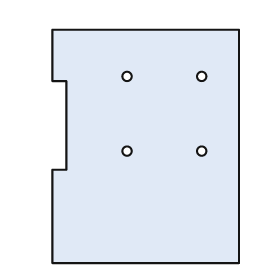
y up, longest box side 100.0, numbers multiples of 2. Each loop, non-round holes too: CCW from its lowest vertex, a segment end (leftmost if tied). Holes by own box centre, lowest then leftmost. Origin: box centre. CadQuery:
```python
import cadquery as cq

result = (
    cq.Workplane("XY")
    .moveTo(-40.0, -50.0)
    .lineTo(40.0, -50.0)
    .lineTo(40.0, 50.0)
    .lineTo(-40.0, 50.0)
    .lineTo(-40.0, 28.0)
    .lineTo(-34.0, 28.0)
    .lineTo(-34.0, -10.0)
    .lineTo(-40.0, -10.0)
    .close()
    .moveTo(-8.0, -2.0)
    .circle(2.0)
    .moveTo(24.0, -2.0)
    .circle(2.0)
    .moveTo(-8.0, 30.0)
    .circle(2.0)
    .moveTo(24.0, 30.0)
    .circle(2.0)
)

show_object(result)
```